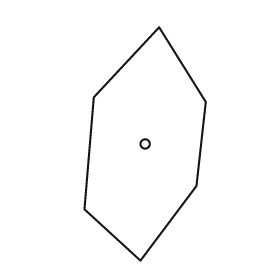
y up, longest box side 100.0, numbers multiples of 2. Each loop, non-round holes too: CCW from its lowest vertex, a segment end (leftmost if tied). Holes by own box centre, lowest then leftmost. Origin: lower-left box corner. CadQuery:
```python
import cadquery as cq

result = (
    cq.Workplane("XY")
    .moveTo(24.0, 0.0)
    .lineTo(48.0, 32.0)
    .lineTo(52.0, 68.0)
    .lineTo(32.0, 100.0)
    .lineTo(4.0, 70.0)
    .lineTo(0.0, 22.0)
    .close()
    .moveTo(26.0, 50.0)
    .circle(2.0)
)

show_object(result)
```